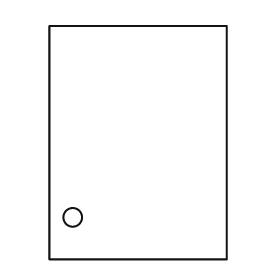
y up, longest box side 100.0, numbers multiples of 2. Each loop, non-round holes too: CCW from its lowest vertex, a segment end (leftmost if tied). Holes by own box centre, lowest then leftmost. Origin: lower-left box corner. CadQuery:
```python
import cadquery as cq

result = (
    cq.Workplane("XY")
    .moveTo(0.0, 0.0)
    .lineTo(76.0, 0.0)
    .lineTo(76.0, 100.0)
    .lineTo(0.0, 100.0)
    .close()
    .moveTo(10.0, 18.0)
    .circle(4.0)
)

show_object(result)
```